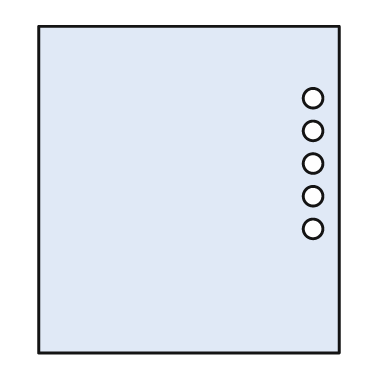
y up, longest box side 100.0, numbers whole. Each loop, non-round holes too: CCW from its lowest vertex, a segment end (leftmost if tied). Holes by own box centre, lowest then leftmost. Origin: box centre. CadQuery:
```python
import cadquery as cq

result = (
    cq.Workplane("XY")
    .moveTo(-46.0, -50.0)
    .lineTo(46.0, -50.0)
    .lineTo(46.0, 50.0)
    .lineTo(-46.0, 50.0)
    .close()
    .moveTo(38.0, -12.0)
    .circle(3.0)
    .moveTo(38.0, -2.0)
    .circle(3.0)
    .moveTo(38.0, 8.0)
    .circle(3.0)
    .moveTo(38.0, 18.0)
    .circle(3.0)
    .moveTo(38.0, 28.0)
    .circle(3.0)
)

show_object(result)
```